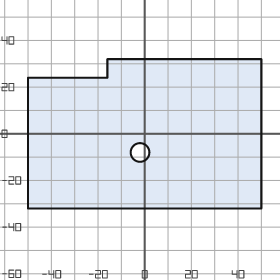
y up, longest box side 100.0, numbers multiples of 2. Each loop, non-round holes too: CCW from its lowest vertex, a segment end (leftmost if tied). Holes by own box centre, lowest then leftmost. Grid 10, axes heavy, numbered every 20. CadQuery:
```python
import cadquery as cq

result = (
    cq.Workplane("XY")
    .moveTo(-50.0, -32.0)
    .lineTo(50.0, -32.0)
    .lineTo(50.0, 32.0)
    .lineTo(-16.0, 32.0)
    .lineTo(-16.0, 24.0)
    .lineTo(-50.0, 24.0)
    .close()
    .moveTo(-2.0, -8.0)
    .circle(4.0)
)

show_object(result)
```